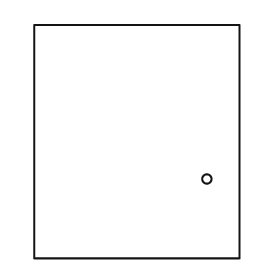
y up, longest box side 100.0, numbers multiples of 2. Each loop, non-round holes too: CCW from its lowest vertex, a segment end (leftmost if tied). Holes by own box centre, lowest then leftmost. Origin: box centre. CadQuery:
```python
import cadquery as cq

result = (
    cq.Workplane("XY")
    .moveTo(-44.0, -50.0)
    .lineTo(44.0, -50.0)
    .lineTo(44.0, 50.0)
    .lineTo(-44.0, 50.0)
    .close()
    .moveTo(30.0, -16.0)
    .circle(2.0)
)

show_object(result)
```